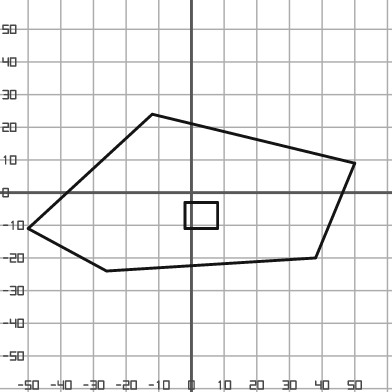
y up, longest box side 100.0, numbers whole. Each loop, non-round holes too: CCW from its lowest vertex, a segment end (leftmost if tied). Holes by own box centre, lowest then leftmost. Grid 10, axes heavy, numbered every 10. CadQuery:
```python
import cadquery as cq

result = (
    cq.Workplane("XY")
    .moveTo(-26.0, -24.0)
    .lineTo(38.0, -20.0)
    .lineTo(50.0, 9.0)
    .lineTo(-12.0, 24.0)
    .lineTo(-50.0, -11.0)
    .close()
    .moveTo(-2.0, -11.0)
    .lineTo(8.0, -11.0)
    .lineTo(8.0, -3.0)
    .lineTo(-2.0, -3.0)
    .close()
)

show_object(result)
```